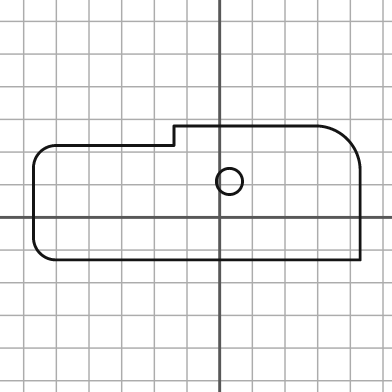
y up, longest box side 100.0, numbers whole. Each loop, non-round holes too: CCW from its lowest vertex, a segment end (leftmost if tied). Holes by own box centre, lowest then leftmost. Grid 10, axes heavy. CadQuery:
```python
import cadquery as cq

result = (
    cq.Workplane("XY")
    .moveTo(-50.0, -13.0)
    .lineTo(43.0, -13.0)
    .lineTo(43.0, 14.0)
    .threePointArc((39.0, 24.0), (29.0, 28.0))
    .lineTo(-14.0, 28.0)
    .lineTo(-14.0, 22.0)
    .lineTo(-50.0, 22.0)
    .threePointArc((-55.0, 20.0), (-57.0, 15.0))
    .lineTo(-57.0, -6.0)
    .threePointArc((-55.0, -11.0), (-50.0, -13.0))
    .close()
    .moveTo(3.0, 11.0)
    .circle(4.0)
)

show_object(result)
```